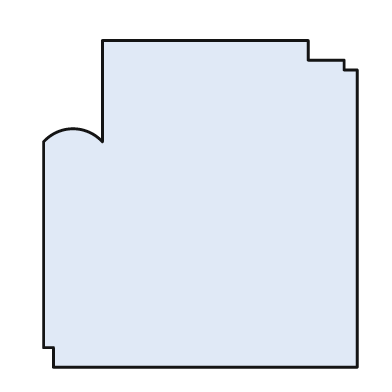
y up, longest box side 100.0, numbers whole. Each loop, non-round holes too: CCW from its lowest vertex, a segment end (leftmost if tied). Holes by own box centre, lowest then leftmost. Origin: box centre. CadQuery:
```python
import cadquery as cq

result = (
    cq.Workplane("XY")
    .moveTo(-45.0, -50.0)
    .lineTo(48.0, -50.0)
    .lineTo(48.0, 41.0)
    .lineTo(44.0, 41.0)
    .lineTo(44.0, 44.0)
    .lineTo(33.0, 44.0)
    .lineTo(33.0, 50.0)
    .lineTo(-30.0, 50.0)
    .lineTo(-30.0, 19.0)
    .threePointArc((-39.0, 23.0), (-48.0, 19.0))
    .lineTo(-48.0, -44.0)
    .lineTo(-45.0, -44.0)
    .close()
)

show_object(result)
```